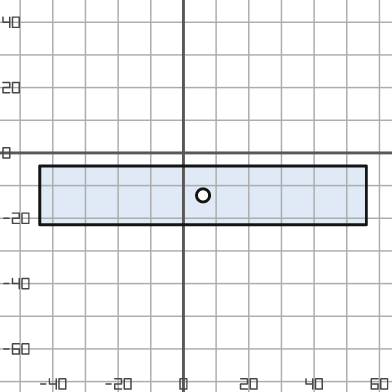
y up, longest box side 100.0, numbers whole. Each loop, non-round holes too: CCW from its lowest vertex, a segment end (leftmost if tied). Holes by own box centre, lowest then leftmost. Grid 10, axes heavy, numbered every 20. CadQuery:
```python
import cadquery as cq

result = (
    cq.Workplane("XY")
    .moveTo(-44.0, -22.0)
    .lineTo(56.0, -22.0)
    .lineTo(56.0, -4.0)
    .lineTo(-44.0, -4.0)
    .close()
    .moveTo(6.0, -13.0)
    .circle(2.0)
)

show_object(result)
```